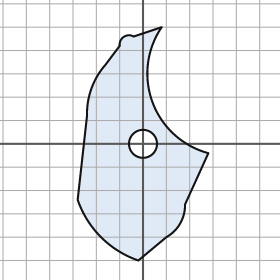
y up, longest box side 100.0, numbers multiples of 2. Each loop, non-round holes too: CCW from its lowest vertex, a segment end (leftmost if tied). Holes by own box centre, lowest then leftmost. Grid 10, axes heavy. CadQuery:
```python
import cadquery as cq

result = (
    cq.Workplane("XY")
    .moveTo(-2.0, -50.0)
    .lineTo(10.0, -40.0)
    .threePointArc((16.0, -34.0), (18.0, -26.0))
    .lineTo(28.0, -4.0)
    .threePointArc((4.0, 18.0), (8.0, 50.0))
    .lineTo(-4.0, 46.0)
    .threePointArc((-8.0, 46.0), (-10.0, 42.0))
    .lineTo(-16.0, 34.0)
    .threePointArc((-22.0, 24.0), (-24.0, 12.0))
    .lineTo(-28.0, -24.0)
    .threePointArc((-18.0, -40.0), (-2.0, -50.0))
    .close()
    .moveTo(0.0, 0.0)
    .circle(6.0)
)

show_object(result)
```